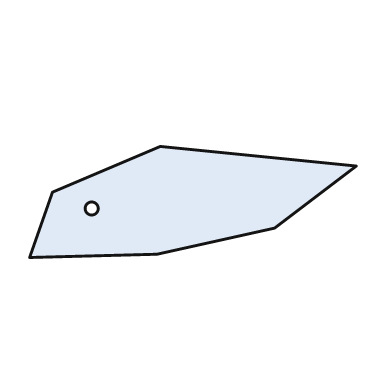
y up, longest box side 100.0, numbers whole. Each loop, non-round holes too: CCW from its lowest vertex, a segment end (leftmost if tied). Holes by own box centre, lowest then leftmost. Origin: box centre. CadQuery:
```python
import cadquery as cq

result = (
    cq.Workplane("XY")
    .moveTo(-50.0, -17.0)
    .lineTo(-11.0, -16.0)
    .lineTo(25.0, -8.0)
    .lineTo(50.0, 11.0)
    .lineTo(-10.0, 17.0)
    .lineTo(-43.0, 3.0)
    .close()
    .moveTo(-31.0, -2.0)
    .circle(2.0)
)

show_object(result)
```